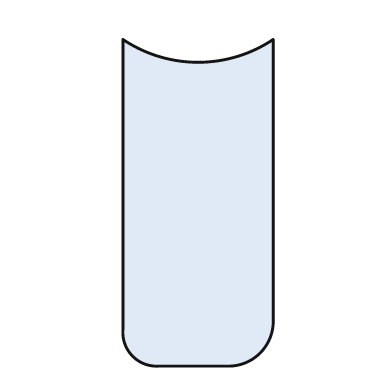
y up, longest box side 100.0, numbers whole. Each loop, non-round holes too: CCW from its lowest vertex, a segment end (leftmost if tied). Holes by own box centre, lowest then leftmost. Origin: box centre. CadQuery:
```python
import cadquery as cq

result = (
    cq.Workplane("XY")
    .moveTo(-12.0, -50.0)
    .lineTo(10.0, -50.0)
    .threePointArc((19.0, -46.0), (23.0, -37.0))
    .lineTo(23.0, 50.0)
    .threePointArc((0.0, 43.0), (-23.0, 50.0))
    .lineTo(-23.0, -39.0)
    .threePointArc((-20.0, -47.0), (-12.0, -50.0))
    .close()
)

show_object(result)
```